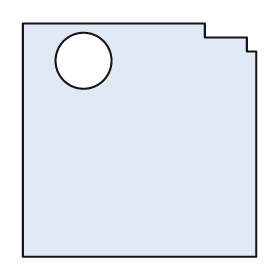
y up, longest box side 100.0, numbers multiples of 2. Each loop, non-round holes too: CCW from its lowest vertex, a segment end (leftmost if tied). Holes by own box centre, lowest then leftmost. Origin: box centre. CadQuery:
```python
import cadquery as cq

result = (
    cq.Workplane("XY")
    .moveTo(-50.0, -50.0)
    .lineTo(50.0, -50.0)
    .lineTo(50.0, 38.0)
    .lineTo(46.0, 38.0)
    .lineTo(46.0, 44.0)
    .lineTo(28.0, 44.0)
    .lineTo(28.0, 50.0)
    .lineTo(-50.0, 50.0)
    .close()
    .moveTo(-24.0, 34.0)
    .circle(12.0)
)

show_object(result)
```